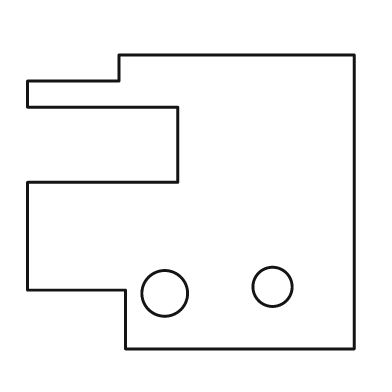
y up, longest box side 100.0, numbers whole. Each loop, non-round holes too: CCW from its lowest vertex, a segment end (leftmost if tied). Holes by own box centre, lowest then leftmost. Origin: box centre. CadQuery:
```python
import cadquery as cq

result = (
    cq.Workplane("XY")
    .moveTo(-20.0, -45.0)
    .lineTo(50.0, -45.0)
    .lineTo(50.0, 45.0)
    .lineTo(-22.0, 45.0)
    .lineTo(-22.0, 37.0)
    .lineTo(-50.0, 37.0)
    .lineTo(-50.0, 29.0)
    .lineTo(-4.0, 29.0)
    .lineTo(-4.0, 6.0)
    .lineTo(-50.0, 6.0)
    .lineTo(-50.0, -27.0)
    .lineTo(-20.0, -27.0)
    .close()
    .moveTo(-8.0, -28.0)
    .circle(7.0)
    .moveTo(25.0, -26.0)
    .circle(6.0)
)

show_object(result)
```